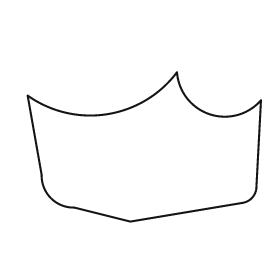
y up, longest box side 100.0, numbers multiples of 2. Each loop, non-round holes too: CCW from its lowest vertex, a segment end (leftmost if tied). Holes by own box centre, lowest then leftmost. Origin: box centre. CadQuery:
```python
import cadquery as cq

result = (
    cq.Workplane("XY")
    .moveTo(-6.0, -32.0)
    .lineTo(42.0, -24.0)
    .threePointArc((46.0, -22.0), (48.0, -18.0))
    .lineTo(50.0, 20.0)
    .threePointArc((28.0, 14.0), (14.0, 32.0))
    .threePointArc((-16.0, 14.0), (-50.0, 22.0))
    .lineTo(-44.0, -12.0)
    .threePointArc((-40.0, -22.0), (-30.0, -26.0))
    .close()
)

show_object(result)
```